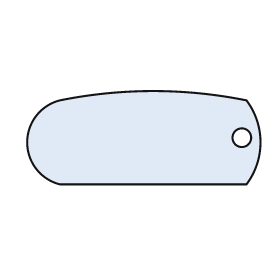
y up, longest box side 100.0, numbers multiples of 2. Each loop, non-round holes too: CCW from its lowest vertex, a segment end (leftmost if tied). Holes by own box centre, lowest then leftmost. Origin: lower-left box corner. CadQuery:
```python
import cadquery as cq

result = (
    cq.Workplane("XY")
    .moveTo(14.0, 0.0)
    .lineTo(94.0, 0.0)
    .threePointArc((100.0, 18.0), (94.0, 36.0))
    .threePointArc((54.0, 40.0), (14.0, 36.0))
    .threePointArc((0.0, 18.0), (14.0, 0.0))
    .close()
    .moveTo(92.0, 20.0)
    .circle(4.0)
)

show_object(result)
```